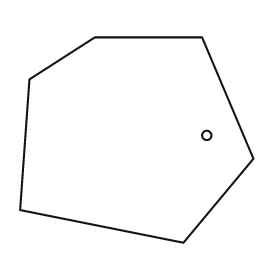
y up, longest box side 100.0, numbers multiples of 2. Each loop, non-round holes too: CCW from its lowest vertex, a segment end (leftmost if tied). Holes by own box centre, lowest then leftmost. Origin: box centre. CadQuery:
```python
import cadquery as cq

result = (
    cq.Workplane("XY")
    .moveTo(20.0, -44.0)
    .lineTo(50.0, -8.0)
    .lineTo(28.0, 44.0)
    .lineTo(-18.0, 44.0)
    .lineTo(-46.0, 26.0)
    .lineTo(-50.0, -30.0)
    .close()
    .moveTo(30.0, 2.0)
    .circle(2.0)
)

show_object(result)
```